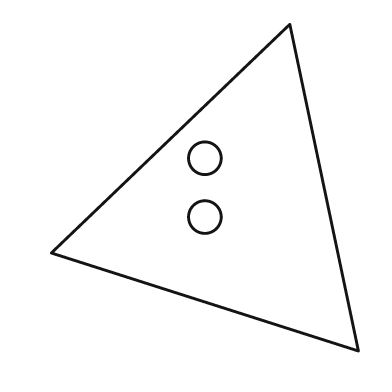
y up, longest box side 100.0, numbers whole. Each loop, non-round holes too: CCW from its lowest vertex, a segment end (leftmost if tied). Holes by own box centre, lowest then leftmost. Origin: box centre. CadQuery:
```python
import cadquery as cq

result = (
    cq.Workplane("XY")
    .moveTo(47.0, -50.0)
    .lineTo(26.0, 50.0)
    .lineTo(-47.0, -20.0)
    .close()
    .moveTo(0.0, -9.0)
    .circle(5.0)
    .moveTo(0.0, 9.0)
    .circle(5.0)
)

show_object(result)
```